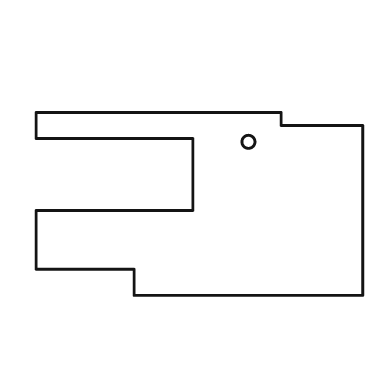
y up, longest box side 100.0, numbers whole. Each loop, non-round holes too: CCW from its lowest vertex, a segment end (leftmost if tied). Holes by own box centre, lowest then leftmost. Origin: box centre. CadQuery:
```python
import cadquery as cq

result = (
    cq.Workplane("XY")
    .moveTo(-20.0, -28.0)
    .lineTo(50.0, -28.0)
    .lineTo(50.0, 24.0)
    .lineTo(25.0, 24.0)
    .lineTo(25.0, 28.0)
    .lineTo(-50.0, 28.0)
    .lineTo(-50.0, 20.0)
    .lineTo(-2.0, 20.0)
    .lineTo(-2.0, -2.0)
    .lineTo(-50.0, -2.0)
    .lineTo(-50.0, -20.0)
    .lineTo(-20.0, -20.0)
    .close()
    .moveTo(15.0, 19.0)
    .circle(2.0)
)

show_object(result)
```